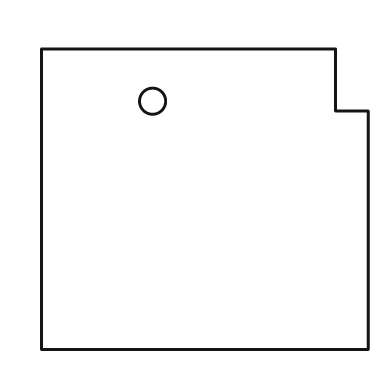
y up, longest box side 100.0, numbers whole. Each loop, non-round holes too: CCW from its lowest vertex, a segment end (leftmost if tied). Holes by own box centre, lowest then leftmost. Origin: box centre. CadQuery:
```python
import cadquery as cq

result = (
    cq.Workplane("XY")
    .moveTo(-50.0, -46.0)
    .lineTo(50.0, -46.0)
    .lineTo(50.0, 27.0)
    .lineTo(40.0, 27.0)
    .lineTo(40.0, 46.0)
    .lineTo(-50.0, 46.0)
    .close()
    .moveTo(-16.0, 30.0)
    .circle(4.0)
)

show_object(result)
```